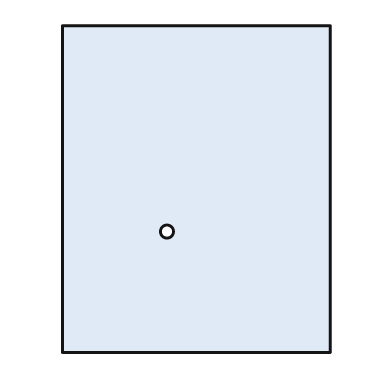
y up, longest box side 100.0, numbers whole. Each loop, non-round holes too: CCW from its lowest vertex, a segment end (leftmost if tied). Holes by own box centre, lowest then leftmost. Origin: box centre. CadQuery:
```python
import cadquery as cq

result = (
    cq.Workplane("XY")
    .moveTo(-41.0, -50.0)
    .lineTo(41.0, -50.0)
    .lineTo(41.0, 50.0)
    .lineTo(-41.0, 50.0)
    .close()
    .moveTo(-9.0, -13.0)
    .circle(2.0)
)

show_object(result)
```